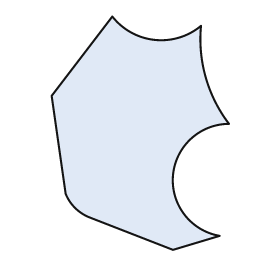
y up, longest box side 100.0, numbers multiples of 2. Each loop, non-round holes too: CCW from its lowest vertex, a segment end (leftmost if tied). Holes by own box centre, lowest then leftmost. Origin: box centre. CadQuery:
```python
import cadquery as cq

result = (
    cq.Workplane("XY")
    .moveTo(14.0, -50.0)
    .lineTo(34.0, -44.0)
    .threePointArc((14.0, -18.0), (38.0, 4.0))
    .threePointArc((28.0, 24.0), (26.0, 46.0))
    .threePointArc((6.0, 40.0), (-12.0, 50.0))
    .lineTo(-38.0, 16.0)
    .lineTo(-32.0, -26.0)
    .threePointArc((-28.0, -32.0), (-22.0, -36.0))
    .close()
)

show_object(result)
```